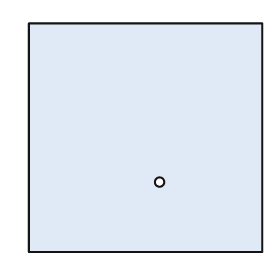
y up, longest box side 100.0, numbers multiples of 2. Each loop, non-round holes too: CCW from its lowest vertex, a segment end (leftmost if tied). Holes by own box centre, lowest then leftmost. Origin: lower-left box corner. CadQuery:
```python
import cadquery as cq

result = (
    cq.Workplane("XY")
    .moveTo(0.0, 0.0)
    .lineTo(100.0, 0.0)
    .lineTo(100.0, 98.0)
    .lineTo(0.0, 98.0)
    .close()
    .moveTo(56.0, 30.0)
    .circle(2.0)
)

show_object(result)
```